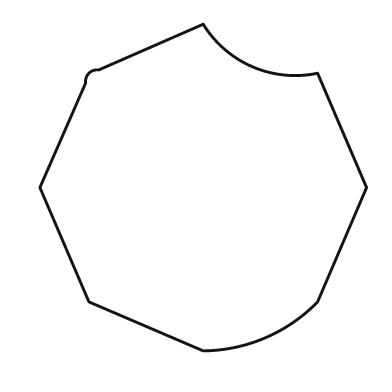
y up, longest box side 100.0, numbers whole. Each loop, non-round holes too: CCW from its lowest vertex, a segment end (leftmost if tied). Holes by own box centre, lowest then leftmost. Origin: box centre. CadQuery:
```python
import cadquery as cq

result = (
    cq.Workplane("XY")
    .moveTo(0.0, -50.0)
    .threePointArc((19.0, -46.0), (35.0, -35.0))
    .lineTo(50.0, 0.0)
    .lineTo(35.0, 35.0)
    .threePointArc((15.0, 37.0), (0.0, 50.0))
    .lineTo(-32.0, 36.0)
    .threePointArc((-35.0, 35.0), (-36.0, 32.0))
    .lineTo(-50.0, 0.0)
    .lineTo(-35.0, -35.0)
    .close()
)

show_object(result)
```